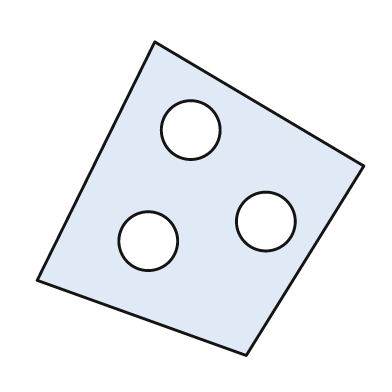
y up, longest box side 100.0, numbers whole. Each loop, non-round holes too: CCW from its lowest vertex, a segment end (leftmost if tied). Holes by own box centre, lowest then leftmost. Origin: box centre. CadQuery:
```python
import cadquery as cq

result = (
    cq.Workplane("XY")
    .moveTo(14.0, -48.0)
    .lineTo(50.0, 10.0)
    .lineTo(-14.0, 48.0)
    .lineTo(-50.0, -25.0)
    .close()
    .moveTo(-16.0, -13.0)
    .circle(9.0)
    .moveTo(20.0, -7.0)
    .circle(9.0)
    .moveTo(-3.0, 21.0)
    .circle(9.0)
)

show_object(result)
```